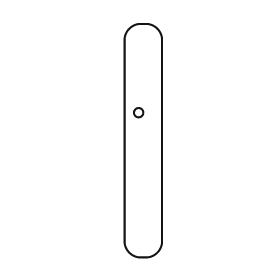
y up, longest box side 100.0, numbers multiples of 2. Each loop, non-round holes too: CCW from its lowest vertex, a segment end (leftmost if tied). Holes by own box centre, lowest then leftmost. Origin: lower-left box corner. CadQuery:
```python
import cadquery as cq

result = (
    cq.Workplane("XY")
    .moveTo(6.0, 0.0)
    .lineTo(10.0, 0.0)
    .threePointArc((14.0, 2.0), (16.0, 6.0))
    .lineTo(16.0, 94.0)
    .threePointArc((14.0, 98.0), (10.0, 100.0))
    .lineTo(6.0, 100.0)
    .threePointArc((2.0, 98.0), (0.0, 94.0))
    .lineTo(0.0, 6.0)
    .threePointArc((2.0, 2.0), (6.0, 0.0))
    .close()
    .moveTo(6.0, 62.0)
    .circle(2.0)
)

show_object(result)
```